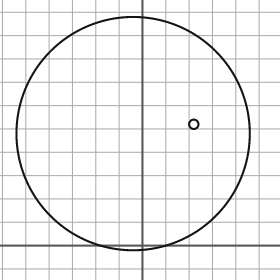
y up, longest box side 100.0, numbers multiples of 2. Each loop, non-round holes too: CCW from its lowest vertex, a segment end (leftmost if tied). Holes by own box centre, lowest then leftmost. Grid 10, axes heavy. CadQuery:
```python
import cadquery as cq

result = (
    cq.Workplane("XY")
    .moveTo(-4.0, 48.0)
    .circle(50.0)
    .moveTo(22.0, 52.0)
    .circle(2.0)
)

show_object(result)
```